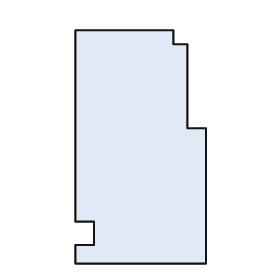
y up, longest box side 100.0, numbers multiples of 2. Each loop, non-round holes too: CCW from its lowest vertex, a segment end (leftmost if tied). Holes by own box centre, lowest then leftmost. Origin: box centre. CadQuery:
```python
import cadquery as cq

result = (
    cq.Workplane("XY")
    .moveTo(-28.0, -50.0)
    .lineTo(28.0, -50.0)
    .lineTo(28.0, 8.0)
    .lineTo(20.0, 8.0)
    .lineTo(20.0, 44.0)
    .lineTo(14.0, 44.0)
    .lineTo(14.0, 50.0)
    .lineTo(-28.0, 50.0)
    .lineTo(-28.0, -32.0)
    .lineTo(-20.0, -32.0)
    .lineTo(-20.0, -42.0)
    .lineTo(-28.0, -42.0)
    .close()
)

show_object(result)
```